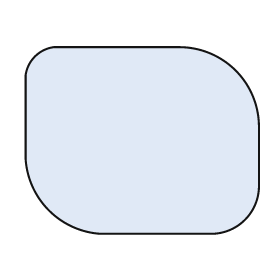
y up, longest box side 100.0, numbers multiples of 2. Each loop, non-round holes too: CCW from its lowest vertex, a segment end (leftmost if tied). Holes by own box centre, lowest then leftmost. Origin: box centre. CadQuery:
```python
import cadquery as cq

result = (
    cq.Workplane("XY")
    .moveTo(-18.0, -40.0)
    .lineTo(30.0, -40.0)
    .threePointArc((44.0, -34.0), (50.0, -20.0))
    .lineTo(50.0, 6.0)
    .threePointArc((40.0, 30.0), (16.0, 40.0))
    .lineTo(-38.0, 40.0)
    .threePointArc((-46.0, 36.0), (-50.0, 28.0))
    .lineTo(-50.0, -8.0)
    .threePointArc((-40.0, -30.0), (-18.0, -40.0))
    .close()
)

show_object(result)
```